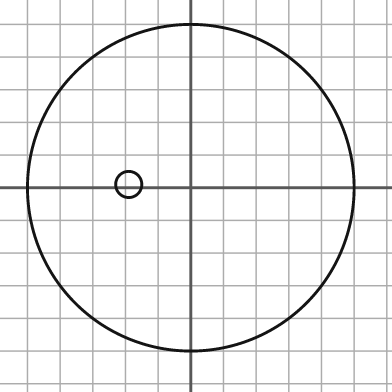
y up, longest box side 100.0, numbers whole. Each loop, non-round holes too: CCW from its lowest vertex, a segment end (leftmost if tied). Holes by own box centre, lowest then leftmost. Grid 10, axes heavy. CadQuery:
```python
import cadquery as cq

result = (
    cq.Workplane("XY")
    .moveTo(0.0, 0.0)
    .circle(50.0)
    .moveTo(-19.0, 1.0)
    .circle(4.0)
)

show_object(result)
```